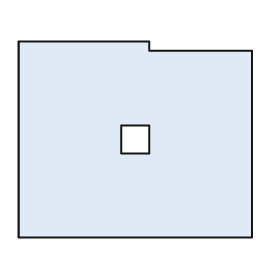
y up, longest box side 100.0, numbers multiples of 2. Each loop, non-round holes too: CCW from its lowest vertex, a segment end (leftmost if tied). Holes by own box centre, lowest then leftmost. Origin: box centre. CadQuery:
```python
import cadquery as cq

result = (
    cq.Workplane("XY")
    .moveTo(-50.0, -42.0)
    .lineTo(50.0, -42.0)
    .lineTo(50.0, 38.0)
    .lineTo(6.0, 38.0)
    .lineTo(6.0, 42.0)
    .lineTo(-50.0, 42.0)
    .close()
    .moveTo(-6.0, -6.0)
    .lineTo(6.0, -6.0)
    .lineTo(6.0, 6.0)
    .lineTo(-6.0, 6.0)
    .close()
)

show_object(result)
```